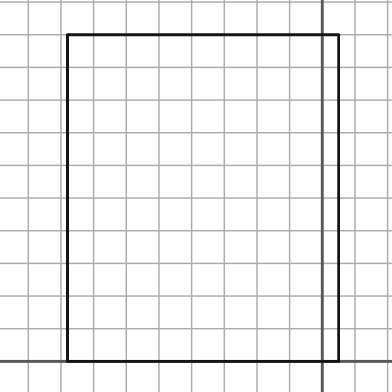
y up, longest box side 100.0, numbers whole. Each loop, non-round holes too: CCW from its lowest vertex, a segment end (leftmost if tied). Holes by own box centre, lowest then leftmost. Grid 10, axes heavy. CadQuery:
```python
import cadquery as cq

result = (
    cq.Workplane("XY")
    .moveTo(-78.0, 0.0)
    .lineTo(5.0, 0.0)
    .lineTo(5.0, 100.0)
    .lineTo(-78.0, 100.0)
    .close()
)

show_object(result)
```